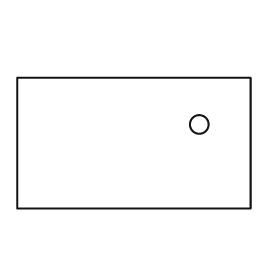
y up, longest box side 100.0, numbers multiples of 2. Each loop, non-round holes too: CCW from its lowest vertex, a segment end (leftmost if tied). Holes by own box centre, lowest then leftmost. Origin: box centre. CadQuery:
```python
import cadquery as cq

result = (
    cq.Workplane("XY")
    .moveTo(-50.0, -28.0)
    .lineTo(50.0, -28.0)
    .lineTo(50.0, 28.0)
    .lineTo(-50.0, 28.0)
    .close()
    .moveTo(28.0, 8.0)
    .circle(4.0)
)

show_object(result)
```